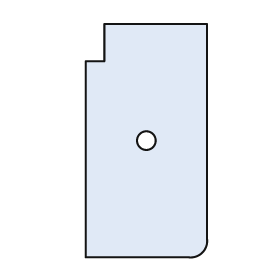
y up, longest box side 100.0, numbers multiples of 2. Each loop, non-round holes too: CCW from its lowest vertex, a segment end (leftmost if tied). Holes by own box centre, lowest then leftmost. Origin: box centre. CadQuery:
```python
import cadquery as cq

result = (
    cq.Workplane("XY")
    .moveTo(-26.0, -50.0)
    .lineTo(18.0, -50.0)
    .threePointArc((24.0, -48.0), (26.0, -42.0))
    .lineTo(26.0, 50.0)
    .lineTo(-18.0, 50.0)
    .lineTo(-18.0, 34.0)
    .lineTo(-26.0, 34.0)
    .close()
    .moveTo(0.0, 0.0)
    .circle(4.0)
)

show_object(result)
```